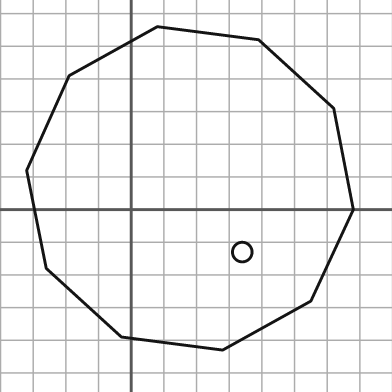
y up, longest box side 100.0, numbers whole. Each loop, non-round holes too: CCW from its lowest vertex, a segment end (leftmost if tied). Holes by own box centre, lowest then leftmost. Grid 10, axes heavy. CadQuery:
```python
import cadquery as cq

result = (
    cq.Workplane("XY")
    .moveTo(28.0, -43.0)
    .lineTo(55.0, -28.0)
    .lineTo(68.0, 0.0)
    .lineTo(62.0, 31.0)
    .lineTo(39.0, 52.0)
    .lineTo(8.0, 56.0)
    .lineTo(-19.0, 41.0)
    .lineTo(-32.0, 12.0)
    .lineTo(-26.0, -18.0)
    .lineTo(-3.0, -39.0)
    .close()
    .moveTo(34.0, -13.0)
    .circle(3.0)
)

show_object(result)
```